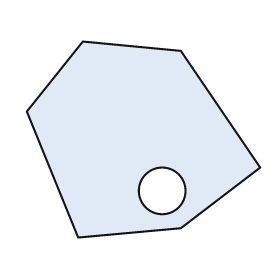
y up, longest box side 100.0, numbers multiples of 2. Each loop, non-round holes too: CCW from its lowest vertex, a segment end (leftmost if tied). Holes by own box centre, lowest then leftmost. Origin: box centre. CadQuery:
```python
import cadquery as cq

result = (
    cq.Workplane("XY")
    .moveTo(-28.0, -42.0)
    .lineTo(16.0, -38.0)
    .lineTo(50.0, -12.0)
    .lineTo(16.0, 38.0)
    .lineTo(-26.0, 42.0)
    .lineTo(-50.0, 12.0)
    .close()
    .moveTo(8.0, -22.0)
    .circle(10.0)
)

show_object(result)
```